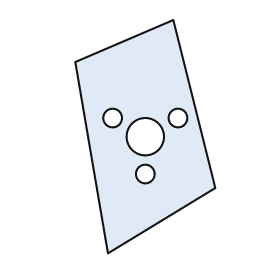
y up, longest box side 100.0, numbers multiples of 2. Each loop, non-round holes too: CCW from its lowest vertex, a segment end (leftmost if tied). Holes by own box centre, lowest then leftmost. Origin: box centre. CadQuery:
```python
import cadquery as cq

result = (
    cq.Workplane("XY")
    .moveTo(-16.0, -50.0)
    .lineTo(30.0, -22.0)
    .lineTo(12.0, 50.0)
    .lineTo(-30.0, 32.0)
    .close()
    .moveTo(0.0, -16.0)
    .circle(4.0)
    .moveTo(0.0, 0.0)
    .circle(8.0)
    .moveTo(-14.0, 8.0)
    .circle(4.0)
    .moveTo(14.0, 8.0)
    .circle(4.0)
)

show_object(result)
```